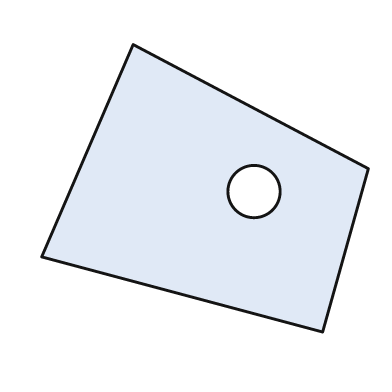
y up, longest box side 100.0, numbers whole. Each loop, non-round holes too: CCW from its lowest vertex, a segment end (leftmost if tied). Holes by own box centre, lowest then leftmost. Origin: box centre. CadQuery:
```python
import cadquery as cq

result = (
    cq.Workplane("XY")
    .moveTo(36.0, -44.0)
    .lineTo(50.0, 6.0)
    .lineTo(-22.0, 44.0)
    .lineTo(-50.0, -21.0)
    .close()
    .moveTo(15.0, -1.0)
    .circle(8.0)
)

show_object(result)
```